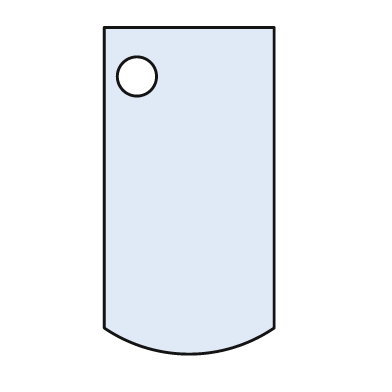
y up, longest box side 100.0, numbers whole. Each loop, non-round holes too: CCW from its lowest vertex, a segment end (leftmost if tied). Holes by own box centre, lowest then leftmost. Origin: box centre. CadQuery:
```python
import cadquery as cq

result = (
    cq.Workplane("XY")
    .moveTo(-26.0, -42.0)
    .threePointArc((0.0, -50.0), (26.0, -42.0))
    .lineTo(26.0, 50.0)
    .lineTo(-26.0, 50.0)
    .close()
    .moveTo(-16.0, 35.0)
    .circle(6.0)
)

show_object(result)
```